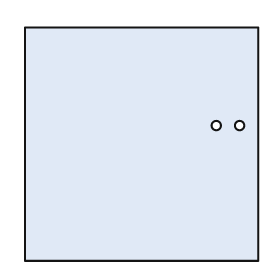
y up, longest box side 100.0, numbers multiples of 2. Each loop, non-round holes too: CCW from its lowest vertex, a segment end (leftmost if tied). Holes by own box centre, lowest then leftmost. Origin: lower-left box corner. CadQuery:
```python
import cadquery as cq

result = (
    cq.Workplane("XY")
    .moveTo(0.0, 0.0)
    .lineTo(100.0, 0.0)
    .lineTo(100.0, 100.0)
    .lineTo(0.0, 100.0)
    .close()
    .moveTo(82.0, 58.0)
    .circle(2.0)
    .moveTo(92.0, 58.0)
    .circle(2.0)
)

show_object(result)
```